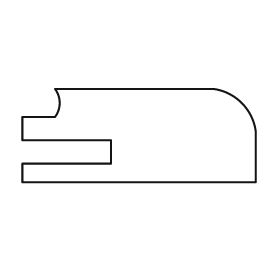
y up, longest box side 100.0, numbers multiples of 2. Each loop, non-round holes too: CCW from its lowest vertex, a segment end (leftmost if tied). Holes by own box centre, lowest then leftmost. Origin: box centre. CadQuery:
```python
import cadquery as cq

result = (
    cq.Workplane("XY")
    .moveTo(-50.0, -20.0)
    .lineTo(50.0, -20.0)
    .lineTo(50.0, 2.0)
    .threePointArc((44.0, 14.0), (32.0, 20.0))
    .lineTo(-36.0, 20.0)
    .threePointArc((-34.0, 14.0), (-36.0, 8.0))
    .lineTo(-50.0, 8.0)
    .lineTo(-50.0, -2.0)
    .lineTo(-12.0, -2.0)
    .lineTo(-12.0, -12.0)
    .lineTo(-50.0, -12.0)
    .close()
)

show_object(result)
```